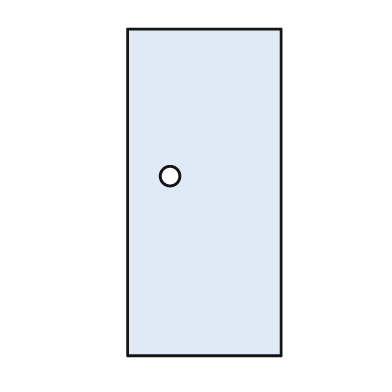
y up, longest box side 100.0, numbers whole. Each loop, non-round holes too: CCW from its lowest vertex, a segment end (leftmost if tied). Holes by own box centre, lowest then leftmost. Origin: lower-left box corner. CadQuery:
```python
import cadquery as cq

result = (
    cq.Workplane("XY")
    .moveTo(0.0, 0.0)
    .lineTo(47.0, 0.0)
    .lineTo(47.0, 100.0)
    .lineTo(0.0, 100.0)
    .close()
    .moveTo(13.0, 55.0)
    .circle(3.0)
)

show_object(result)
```